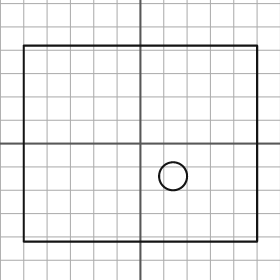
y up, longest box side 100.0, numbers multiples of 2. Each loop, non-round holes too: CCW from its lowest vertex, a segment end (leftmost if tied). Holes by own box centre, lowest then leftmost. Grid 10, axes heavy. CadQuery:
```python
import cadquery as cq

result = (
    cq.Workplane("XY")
    .moveTo(-50.0, -42.0)
    .lineTo(50.0, -42.0)
    .lineTo(50.0, 42.0)
    .lineTo(-50.0, 42.0)
    .close()
    .moveTo(14.0, -14.0)
    .circle(6.0)
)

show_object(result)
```